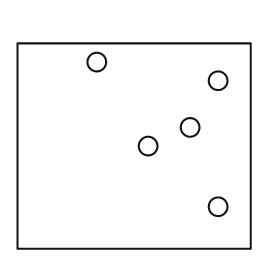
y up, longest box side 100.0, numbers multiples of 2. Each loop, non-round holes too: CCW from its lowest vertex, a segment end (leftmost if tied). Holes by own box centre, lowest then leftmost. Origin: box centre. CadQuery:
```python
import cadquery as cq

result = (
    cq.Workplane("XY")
    .moveTo(-50.0, -44.0)
    .lineTo(50.0, -44.0)
    .lineTo(50.0, 44.0)
    .lineTo(-50.0, 44.0)
    .close()
    .moveTo(36.0, -26.0)
    .circle(4.0)
    .moveTo(6.0, 0.0)
    .circle(4.0)
    .moveTo(24.0, 8.0)
    .circle(4.0)
    .moveTo(36.0, 28.0)
    .circle(4.0)
    .moveTo(-16.0, 36.0)
    .circle(4.0)
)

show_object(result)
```